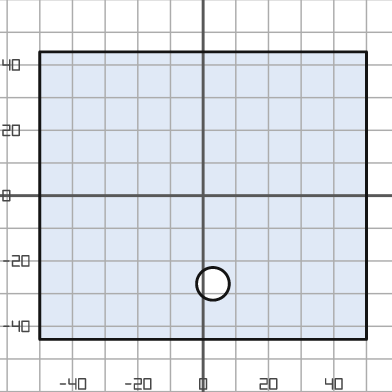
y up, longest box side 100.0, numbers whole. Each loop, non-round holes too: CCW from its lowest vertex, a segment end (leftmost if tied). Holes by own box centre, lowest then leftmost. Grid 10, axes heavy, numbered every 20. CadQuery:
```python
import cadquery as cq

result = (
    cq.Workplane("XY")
    .moveTo(-50.0, -44.0)
    .lineTo(50.0, -44.0)
    .lineTo(50.0, 44.0)
    .lineTo(-50.0, 44.0)
    .close()
    .moveTo(3.0, -27.0)
    .circle(5.0)
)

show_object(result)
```